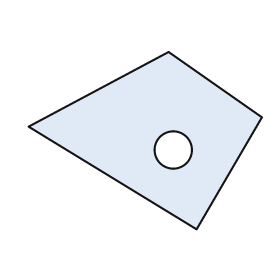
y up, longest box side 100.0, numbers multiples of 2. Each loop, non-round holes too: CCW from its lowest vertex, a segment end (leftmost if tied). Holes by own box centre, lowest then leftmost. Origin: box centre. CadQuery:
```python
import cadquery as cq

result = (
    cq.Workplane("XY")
    .moveTo(22.0, -38.0)
    .lineTo(50.0, 10.0)
    .lineTo(10.0, 38.0)
    .lineTo(-50.0, 6.0)
    .close()
    .moveTo(12.0, -4.0)
    .circle(8.0)
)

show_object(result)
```